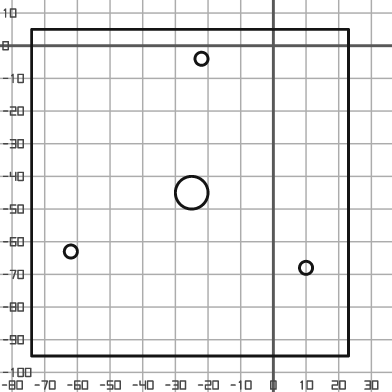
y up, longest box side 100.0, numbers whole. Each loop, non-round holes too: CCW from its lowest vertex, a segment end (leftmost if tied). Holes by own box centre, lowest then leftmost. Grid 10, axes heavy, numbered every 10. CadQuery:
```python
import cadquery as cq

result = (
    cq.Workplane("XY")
    .moveTo(-74.0, -95.0)
    .lineTo(23.0, -95.0)
    .lineTo(23.0, 5.0)
    .lineTo(-74.0, 5.0)
    .close()
    .moveTo(10.0, -68.0)
    .circle(2.0)
    .moveTo(-62.0, -63.0)
    .circle(2.0)
    .moveTo(-25.0, -45.0)
    .circle(5.0)
    .moveTo(-22.0, -4.0)
    .circle(2.0)
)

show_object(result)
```